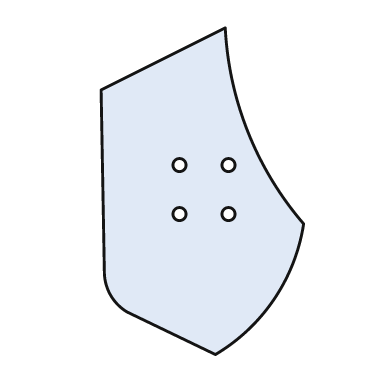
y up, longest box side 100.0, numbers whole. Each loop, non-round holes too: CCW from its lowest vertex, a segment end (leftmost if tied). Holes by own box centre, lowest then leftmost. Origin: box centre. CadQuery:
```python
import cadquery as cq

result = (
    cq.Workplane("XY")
    .moveTo(4.0, -50.0)
    .threePointArc((22.0, -33.0), (31.0, -10.0))
    .threePointArc((14.0, 18.0), (7.0, 50.0))
    .lineTo(-31.0, 31.0)
    .lineTo(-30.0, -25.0)
    .threePointArc((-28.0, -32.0), (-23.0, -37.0))
    .close()
    .moveTo(-7.0, -7.0)
    .circle(2.0)
    .moveTo(8.0, -7.0)
    .circle(2.0)
    .moveTo(-7.0, 8.0)
    .circle(2.0)
    .moveTo(8.0, 8.0)
    .circle(2.0)
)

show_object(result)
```